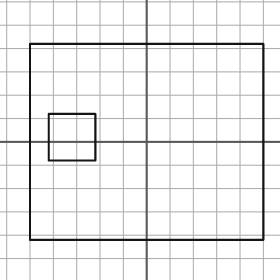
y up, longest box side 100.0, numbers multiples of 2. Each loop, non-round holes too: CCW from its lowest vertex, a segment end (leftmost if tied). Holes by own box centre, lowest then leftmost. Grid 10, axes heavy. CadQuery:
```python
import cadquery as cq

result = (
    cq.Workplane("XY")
    .moveTo(-50.0, -42.0)
    .lineTo(50.0, -42.0)
    .lineTo(50.0, 42.0)
    .lineTo(-50.0, 42.0)
    .close()
    .moveTo(-42.0, -8.0)
    .lineTo(-22.0, -8.0)
    .lineTo(-22.0, 12.0)
    .lineTo(-42.0, 12.0)
    .close()
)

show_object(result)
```